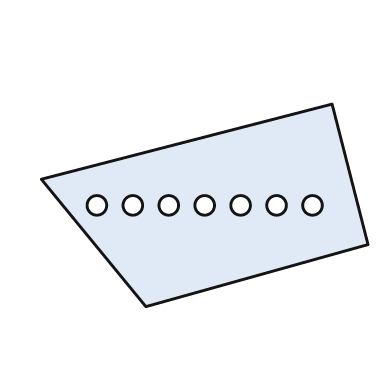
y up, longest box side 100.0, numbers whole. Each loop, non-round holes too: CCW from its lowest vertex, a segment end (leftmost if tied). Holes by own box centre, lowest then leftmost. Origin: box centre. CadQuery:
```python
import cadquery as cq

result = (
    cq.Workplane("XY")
    .moveTo(-18.0, -31.0)
    .lineTo(50.0, -12.0)
    .lineTo(39.0, 31.0)
    .lineTo(-50.0, 8.0)
    .close()
    .moveTo(-33.0, 0.0)
    .circle(3.0)
    .moveTo(-22.0, 0.0)
    .circle(3.0)
    .moveTo(-11.0, 0.0)
    .circle(3.0)
    .moveTo(0.0, 0.0)
    .circle(3.0)
    .moveTo(11.0, 0.0)
    .circle(3.0)
    .moveTo(22.0, 0.0)
    .circle(3.0)
    .moveTo(33.0, 0.0)
    .circle(3.0)
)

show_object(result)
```